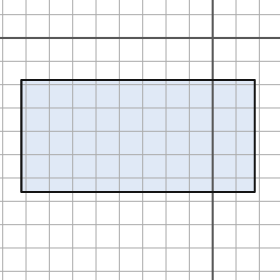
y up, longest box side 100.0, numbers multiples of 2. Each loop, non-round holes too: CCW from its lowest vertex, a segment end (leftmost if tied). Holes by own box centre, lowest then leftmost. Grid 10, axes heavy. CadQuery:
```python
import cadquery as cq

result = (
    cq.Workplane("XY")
    .moveTo(-82.0, -66.0)
    .lineTo(18.0, -66.0)
    .lineTo(18.0, -18.0)
    .lineTo(-82.0, -18.0)
    .close()
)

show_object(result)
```